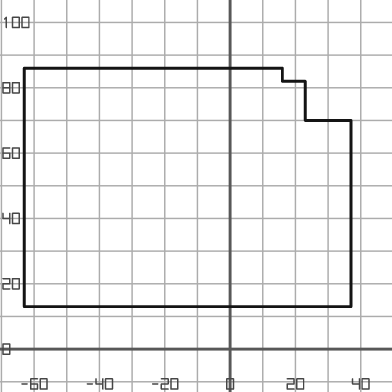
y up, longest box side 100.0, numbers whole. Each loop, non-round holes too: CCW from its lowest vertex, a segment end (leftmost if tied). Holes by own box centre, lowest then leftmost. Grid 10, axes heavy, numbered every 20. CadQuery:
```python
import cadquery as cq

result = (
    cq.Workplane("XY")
    .moveTo(-63.0, 13.0)
    .lineTo(37.0, 13.0)
    .lineTo(37.0, 70.0)
    .lineTo(23.0, 70.0)
    .lineTo(23.0, 82.0)
    .lineTo(16.0, 82.0)
    .lineTo(16.0, 86.0)
    .lineTo(-63.0, 86.0)
    .close()
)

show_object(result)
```